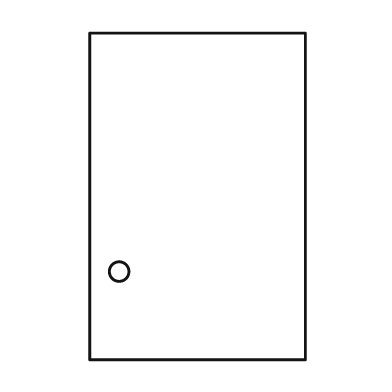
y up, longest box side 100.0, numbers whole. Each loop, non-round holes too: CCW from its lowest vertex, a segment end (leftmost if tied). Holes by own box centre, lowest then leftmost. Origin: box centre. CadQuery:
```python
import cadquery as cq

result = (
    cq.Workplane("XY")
    .moveTo(-33.0, -50.0)
    .lineTo(33.0, -50.0)
    .lineTo(33.0, 50.0)
    .lineTo(-33.0, 50.0)
    .close()
    .moveTo(-24.0, -23.0)
    .circle(3.0)
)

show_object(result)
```